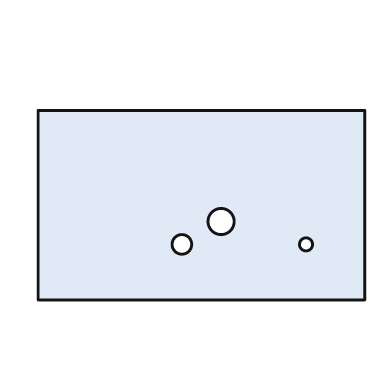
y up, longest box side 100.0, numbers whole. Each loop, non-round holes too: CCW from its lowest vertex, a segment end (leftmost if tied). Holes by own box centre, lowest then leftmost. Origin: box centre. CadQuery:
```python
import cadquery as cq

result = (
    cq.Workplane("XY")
    .moveTo(-50.0, -29.0)
    .lineTo(50.0, -29.0)
    .lineTo(50.0, 29.0)
    .lineTo(-50.0, 29.0)
    .close()
    .moveTo(-6.0, -12.0)
    .circle(3.0)
    .moveTo(32.0, -12.0)
    .circle(2.0)
    .moveTo(6.0, -5.0)
    .circle(4.0)
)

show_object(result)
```